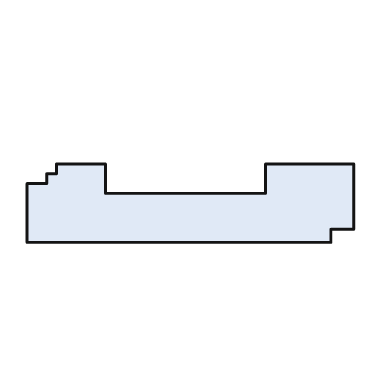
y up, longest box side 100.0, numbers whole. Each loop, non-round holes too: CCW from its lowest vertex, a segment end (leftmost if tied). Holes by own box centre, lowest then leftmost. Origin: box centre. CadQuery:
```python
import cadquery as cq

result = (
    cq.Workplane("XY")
    .moveTo(-50.0, -12.0)
    .lineTo(43.0, -12.0)
    .lineTo(43.0, -8.0)
    .lineTo(50.0, -8.0)
    .lineTo(50.0, 12.0)
    .lineTo(23.0, 12.0)
    .lineTo(23.0, 3.0)
    .lineTo(-26.0, 3.0)
    .lineTo(-26.0, 12.0)
    .lineTo(-41.0, 12.0)
    .lineTo(-41.0, 9.0)
    .lineTo(-44.0, 9.0)
    .lineTo(-44.0, 6.0)
    .lineTo(-50.0, 6.0)
    .close()
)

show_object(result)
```